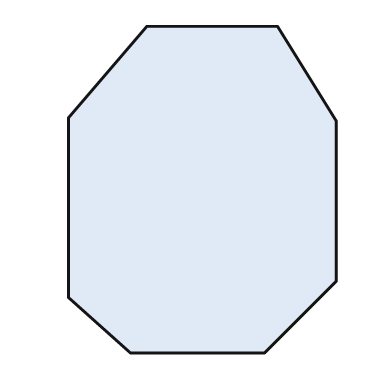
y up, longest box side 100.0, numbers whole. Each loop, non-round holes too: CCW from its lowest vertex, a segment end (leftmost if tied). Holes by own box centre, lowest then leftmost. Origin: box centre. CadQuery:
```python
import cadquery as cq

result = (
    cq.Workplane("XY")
    .moveTo(-22.0, -50.0)
    .lineTo(19.0, -50.0)
    .lineTo(41.0, -28.0)
    .lineTo(41.0, 21.0)
    .lineTo(23.0, 50.0)
    .lineTo(-17.0, 50.0)
    .lineTo(-41.0, 22.0)
    .lineTo(-41.0, -33.0)
    .close()
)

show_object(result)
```